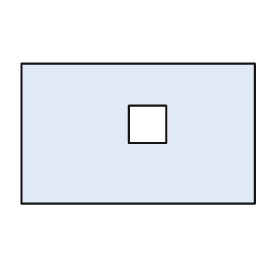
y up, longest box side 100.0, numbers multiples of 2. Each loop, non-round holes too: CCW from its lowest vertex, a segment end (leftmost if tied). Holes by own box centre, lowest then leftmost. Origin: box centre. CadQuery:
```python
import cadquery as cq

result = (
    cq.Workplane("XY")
    .moveTo(-50.0, -30.0)
    .lineTo(50.0, -30.0)
    .lineTo(50.0, 30.0)
    .lineTo(-50.0, 30.0)
    .close()
    .moveTo(-4.0, -4.0)
    .lineTo(12.0, -4.0)
    .lineTo(12.0, 12.0)
    .lineTo(-4.0, 12.0)
    .close()
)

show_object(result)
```